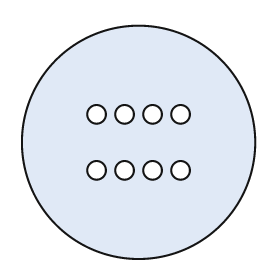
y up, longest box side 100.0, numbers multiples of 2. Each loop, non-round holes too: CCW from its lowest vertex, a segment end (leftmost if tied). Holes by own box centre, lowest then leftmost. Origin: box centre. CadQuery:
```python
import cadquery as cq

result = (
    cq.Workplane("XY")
    .moveTo(0.0, 0.0)
    .circle(50.0)
    .moveTo(-18.0, -12.0)
    .circle(4.0)
    .moveTo(-6.0, -12.0)
    .circle(4.0)
    .moveTo(6.0, -12.0)
    .circle(4.0)
    .moveTo(18.0, -12.0)
    .circle(4.0)
    .moveTo(-18.0, 12.0)
    .circle(4.0)
    .moveTo(-6.0, 12.0)
    .circle(4.0)
    .moveTo(6.0, 12.0)
    .circle(4.0)
    .moveTo(18.0, 12.0)
    .circle(4.0)
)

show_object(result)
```